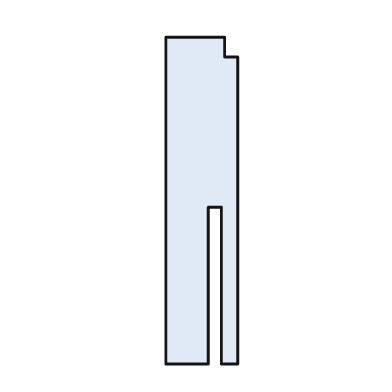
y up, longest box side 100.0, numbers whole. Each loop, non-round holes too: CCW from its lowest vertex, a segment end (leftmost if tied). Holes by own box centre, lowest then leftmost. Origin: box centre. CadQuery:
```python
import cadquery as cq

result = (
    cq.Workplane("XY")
    .moveTo(-11.0, -50.0)
    .lineTo(2.0, -50.0)
    .lineTo(2.0, -2.0)
    .lineTo(6.0, -2.0)
    .lineTo(6.0, -50.0)
    .lineTo(11.0, -50.0)
    .lineTo(11.0, 44.0)
    .lineTo(7.0, 44.0)
    .lineTo(7.0, 50.0)
    .lineTo(-11.0, 50.0)
    .close()
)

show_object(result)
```